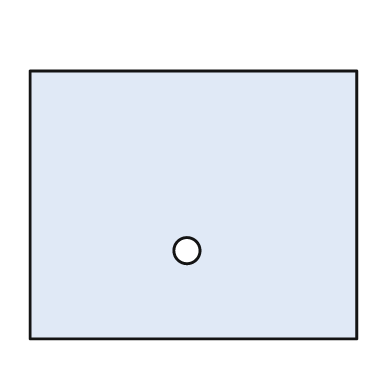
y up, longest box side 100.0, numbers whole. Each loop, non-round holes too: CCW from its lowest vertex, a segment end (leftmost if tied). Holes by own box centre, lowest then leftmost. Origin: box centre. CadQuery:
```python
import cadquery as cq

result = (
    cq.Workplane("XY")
    .moveTo(-50.0, -41.0)
    .lineTo(50.0, -41.0)
    .lineTo(50.0, 41.0)
    .lineTo(-50.0, 41.0)
    .close()
    .moveTo(-2.0, -14.0)
    .circle(4.0)
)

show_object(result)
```